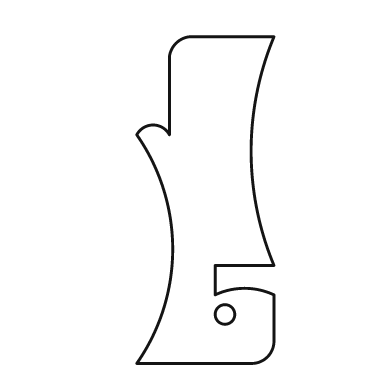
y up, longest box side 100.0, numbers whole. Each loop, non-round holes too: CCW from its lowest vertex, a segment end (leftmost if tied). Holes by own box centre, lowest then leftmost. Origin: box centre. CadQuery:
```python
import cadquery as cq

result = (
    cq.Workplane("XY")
    .moveTo(-21.0, -50.0)
    .lineTo(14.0, -50.0)
    .threePointArc((19.0, -48.0), (21.0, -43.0))
    .lineTo(21.0, -29.0)
    .threePointArc((12.0, -27.0), (3.0, -29.0))
    .lineTo(3.0, -20.0)
    .lineTo(21.0, -20.0)
    .threePointArc((14.0, 15.0), (21.0, 50.0))
    .lineTo(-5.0, 50.0)
    .threePointArc((-9.0, 48.0), (-11.0, 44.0))
    .lineTo(-11.0, 20.0)
    .threePointArc((-16.0, 23.0), (-21.0, 20.0))
    .threePointArc((-10.0, -15.0), (-21.0, -50.0))
    .close()
    .moveTo(6.0, -35.0)
    .circle(3.0)
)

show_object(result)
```